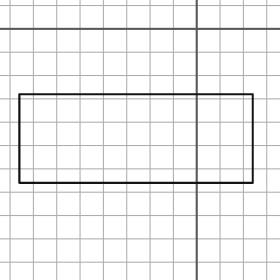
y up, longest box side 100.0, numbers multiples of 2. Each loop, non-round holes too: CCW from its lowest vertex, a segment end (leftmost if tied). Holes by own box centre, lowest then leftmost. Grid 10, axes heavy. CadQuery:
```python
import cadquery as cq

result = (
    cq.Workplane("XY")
    .moveTo(-76.0, -66.0)
    .lineTo(24.0, -66.0)
    .lineTo(24.0, -28.0)
    .lineTo(-76.0, -28.0)
    .close()
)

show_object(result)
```